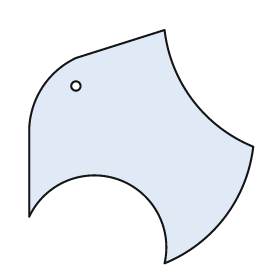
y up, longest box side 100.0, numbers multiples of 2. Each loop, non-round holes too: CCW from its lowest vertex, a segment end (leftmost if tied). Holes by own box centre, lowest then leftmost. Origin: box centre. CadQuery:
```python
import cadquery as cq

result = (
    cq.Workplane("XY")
    .moveTo(10.0, -50.0)
    .threePointArc((36.0, -30.0), (48.0, 0.0))
    .threePointArc((22.0, 20.0), (10.0, 50.0))
    .lineTo(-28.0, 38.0)
    .threePointArc((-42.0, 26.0), (-48.0, 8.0))
    .lineTo(-48.0, -30.0)
    .threePointArc((-10.0, -14.0), (10.0, -50.0))
    .close()
    .moveTo(-28.0, 26.0)
    .circle(2.0)
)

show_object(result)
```